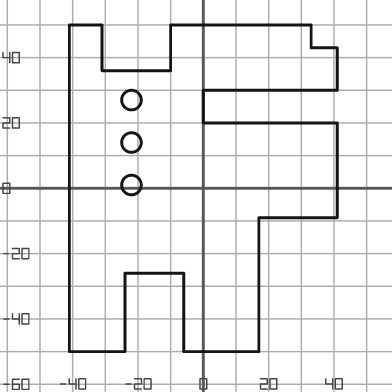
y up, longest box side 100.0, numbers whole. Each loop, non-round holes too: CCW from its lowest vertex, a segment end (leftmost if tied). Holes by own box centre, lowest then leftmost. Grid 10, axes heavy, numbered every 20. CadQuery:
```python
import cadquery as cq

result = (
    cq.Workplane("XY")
    .moveTo(-41.0, -50.0)
    .lineTo(-24.0, -50.0)
    .lineTo(-24.0, -26.0)
    .lineTo(-6.0, -26.0)
    .lineTo(-6.0, -50.0)
    .lineTo(17.0, -50.0)
    .lineTo(17.0, -9.0)
    .lineTo(41.0, -9.0)
    .lineTo(41.0, 20.0)
    .lineTo(0.0, 20.0)
    .lineTo(0.0, 30.0)
    .lineTo(41.0, 30.0)
    .lineTo(41.0, 43.0)
    .lineTo(33.0, 43.0)
    .lineTo(33.0, 50.0)
    .lineTo(-10.0, 50.0)
    .lineTo(-10.0, 36.0)
    .lineTo(-31.0, 36.0)
    .lineTo(-31.0, 50.0)
    .lineTo(-41.0, 50.0)
    .close()
    .moveTo(-22.0, 1.0)
    .circle(3.0)
    .moveTo(-22.0, 14.0)
    .circle(3.0)
    .moveTo(-22.0, 27.0)
    .circle(3.0)
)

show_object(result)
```